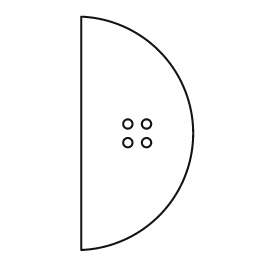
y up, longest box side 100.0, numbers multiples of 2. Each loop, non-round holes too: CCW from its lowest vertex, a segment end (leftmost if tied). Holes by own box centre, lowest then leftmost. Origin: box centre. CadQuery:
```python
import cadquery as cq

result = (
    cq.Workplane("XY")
    .moveTo(-24.0, -50.0)
    .threePointArc((24.0, 0.0), (-24.0, 50.0))
    .close()
    .moveTo(-4.0, -4.0)
    .circle(2.0)
    .moveTo(4.0, -4.0)
    .circle(2.0)
    .moveTo(-4.0, 4.0)
    .circle(2.0)
    .moveTo(4.0, 4.0)
    .circle(2.0)
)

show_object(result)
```